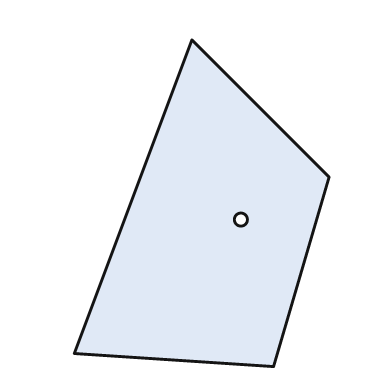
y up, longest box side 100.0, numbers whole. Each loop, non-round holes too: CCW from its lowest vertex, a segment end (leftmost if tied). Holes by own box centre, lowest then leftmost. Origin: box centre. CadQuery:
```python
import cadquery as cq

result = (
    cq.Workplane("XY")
    .moveTo(22.0, -50.0)
    .lineTo(39.0, 8.0)
    .lineTo(-3.0, 50.0)
    .lineTo(-39.0, -46.0)
    .close()
    .moveTo(12.0, -5.0)
    .circle(2.0)
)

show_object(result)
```